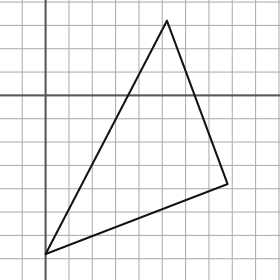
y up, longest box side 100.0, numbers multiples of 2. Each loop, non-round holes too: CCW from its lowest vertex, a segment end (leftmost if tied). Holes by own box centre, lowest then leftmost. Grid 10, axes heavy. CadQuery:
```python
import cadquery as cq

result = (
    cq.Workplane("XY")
    .moveTo(0.0, -68.0)
    .lineTo(78.0, -38.0)
    .lineTo(52.0, 32.0)
    .close()
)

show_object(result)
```